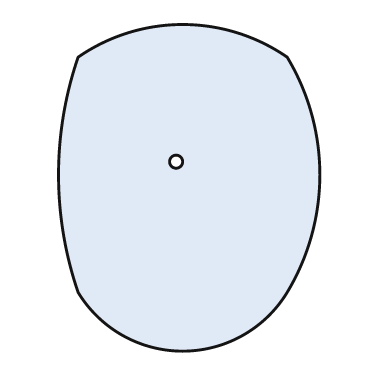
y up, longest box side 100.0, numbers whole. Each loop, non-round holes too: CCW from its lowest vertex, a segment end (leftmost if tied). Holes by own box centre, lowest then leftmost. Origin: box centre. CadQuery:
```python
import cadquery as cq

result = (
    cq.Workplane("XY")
    .moveTo(-34.0, -32.0)
    .threePointArc((-2.0, -50.0), (30.0, -32.0))
    .threePointArc((40.0, 4.0), (30.0, 40.0))
    .threePointArc((-2.0, 50.0), (-34.0, 40.0))
    .threePointArc((-40.0, 4.0), (-34.0, -32.0))
    .close()
    .moveTo(-4.0, 8.0)
    .circle(2.0)
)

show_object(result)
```